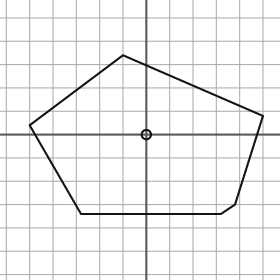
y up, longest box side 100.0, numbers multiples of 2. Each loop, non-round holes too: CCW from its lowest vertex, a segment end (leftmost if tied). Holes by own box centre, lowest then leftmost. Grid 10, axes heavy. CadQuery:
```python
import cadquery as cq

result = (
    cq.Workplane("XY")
    .moveTo(-28.0, -34.0)
    .lineTo(32.0, -34.0)
    .lineTo(38.0, -30.0)
    .lineTo(50.0, 8.0)
    .lineTo(-10.0, 34.0)
    .lineTo(-50.0, 4.0)
    .close()
    .moveTo(0.0, 0.0)
    .circle(2.0)
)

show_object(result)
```